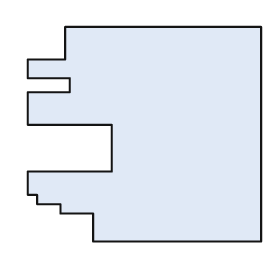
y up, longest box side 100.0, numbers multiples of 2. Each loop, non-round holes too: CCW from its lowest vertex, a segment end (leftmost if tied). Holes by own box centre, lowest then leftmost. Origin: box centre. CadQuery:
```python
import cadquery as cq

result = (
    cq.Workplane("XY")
    .moveTo(-22.0, -46.0)
    .lineTo(50.0, -46.0)
    .lineTo(50.0, 46.0)
    .lineTo(-34.0, 46.0)
    .lineTo(-34.0, 32.0)
    .lineTo(-50.0, 32.0)
    .lineTo(-50.0, 24.0)
    .lineTo(-32.0, 24.0)
    .lineTo(-32.0, 18.0)
    .lineTo(-50.0, 18.0)
    .lineTo(-50.0, 4.0)
    .lineTo(-14.0, 4.0)
    .lineTo(-14.0, -16.0)
    .lineTo(-50.0, -16.0)
    .lineTo(-50.0, -26.0)
    .lineTo(-46.0, -26.0)
    .lineTo(-46.0, -30.0)
    .lineTo(-36.0, -30.0)
    .lineTo(-36.0, -34.0)
    .lineTo(-22.0, -34.0)
    .close()
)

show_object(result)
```